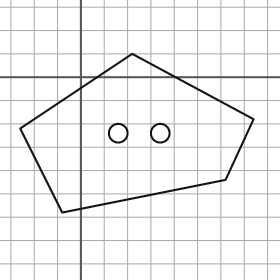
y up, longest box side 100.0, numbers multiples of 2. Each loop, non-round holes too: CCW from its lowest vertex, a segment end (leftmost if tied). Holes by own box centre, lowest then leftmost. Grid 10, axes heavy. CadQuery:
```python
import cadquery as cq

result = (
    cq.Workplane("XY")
    .moveTo(-8.0, -58.0)
    .lineTo(62.0, -44.0)
    .lineTo(74.0, -18.0)
    .lineTo(22.0, 10.0)
    .lineTo(-26.0, -22.0)
    .close()
    .moveTo(16.0, -24.0)
    .circle(4.0)
    .moveTo(34.0, -24.0)
    .circle(4.0)
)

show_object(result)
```